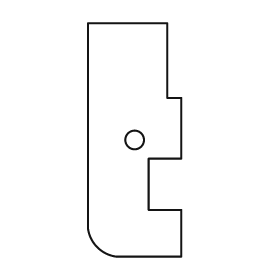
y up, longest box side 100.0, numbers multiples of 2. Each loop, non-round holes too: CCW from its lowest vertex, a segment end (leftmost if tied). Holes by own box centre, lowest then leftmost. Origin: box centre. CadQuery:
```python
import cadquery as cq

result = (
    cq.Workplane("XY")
    .moveTo(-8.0, -50.0)
    .lineTo(20.0, -50.0)
    .lineTo(20.0, -30.0)
    .lineTo(6.0, -30.0)
    .lineTo(6.0, -8.0)
    .lineTo(20.0, -8.0)
    .lineTo(20.0, 18.0)
    .lineTo(14.0, 18.0)
    .lineTo(14.0, 50.0)
    .lineTo(-20.0, 50.0)
    .lineTo(-20.0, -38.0)
    .threePointArc((-16.0, -46.0), (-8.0, -50.0))
    .close()
    .moveTo(0.0, 0.0)
    .circle(4.0)
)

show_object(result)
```